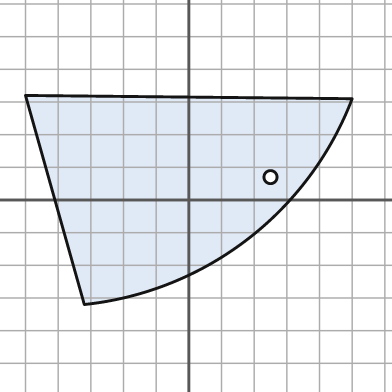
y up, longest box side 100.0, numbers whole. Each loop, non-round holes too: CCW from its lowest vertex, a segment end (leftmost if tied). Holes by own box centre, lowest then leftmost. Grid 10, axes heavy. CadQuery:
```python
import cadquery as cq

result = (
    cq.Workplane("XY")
    .moveTo(-32.0, -32.0)
    .threePointArc((18.0, -12.0), (50.0, 31.0))
    .lineTo(-50.0, 32.0)
    .close()
    .moveTo(25.0, 7.0)
    .circle(2.0)
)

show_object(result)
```